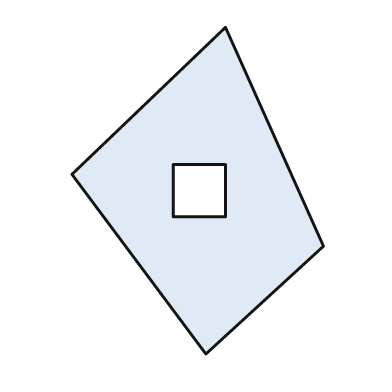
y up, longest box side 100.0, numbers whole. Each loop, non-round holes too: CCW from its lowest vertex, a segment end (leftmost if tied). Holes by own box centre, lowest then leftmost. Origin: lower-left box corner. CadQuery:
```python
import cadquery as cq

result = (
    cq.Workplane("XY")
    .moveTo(41.0, 0.0)
    .lineTo(77.0, 33.0)
    .lineTo(47.0, 100.0)
    .lineTo(0.0, 55.0)
    .close()
    .moveTo(31.0, 42.0)
    .lineTo(47.0, 42.0)
    .lineTo(47.0, 58.0)
    .lineTo(31.0, 58.0)
    .close()
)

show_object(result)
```